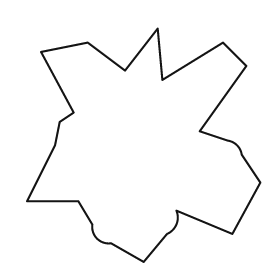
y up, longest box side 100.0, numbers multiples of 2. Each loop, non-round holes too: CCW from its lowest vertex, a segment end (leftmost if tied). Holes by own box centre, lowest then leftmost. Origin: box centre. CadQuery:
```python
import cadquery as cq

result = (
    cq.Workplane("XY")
    .moveTo(0.0, -50.0)
    .lineTo(10.0, -38.0)
    .threePointArc((14.0, -34.0), (14.0, -28.0))
    .lineTo(38.0, -38.0)
    .lineTo(50.0, -16.0)
    .lineTo(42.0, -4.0)
    .threePointArc((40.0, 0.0), (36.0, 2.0))
    .lineTo(24.0, 6.0)
    .lineTo(44.0, 34.0)
    .lineTo(34.0, 44.0)
    .lineTo(8.0, 28.0)
    .lineTo(6.0, 50.0)
    .lineTo(-8.0, 32.0)
    .lineTo(-24.0, 44.0)
    .lineTo(-44.0, 40.0)
    .lineTo(-30.0, 14.0)
    .lineTo(-36.0, 10.0)
    .lineTo(-38.0, 0.0)
    .lineTo(-50.0, -24.0)
    .lineTo(-28.0, -24.0)
    .lineTo(-22.0, -34.0)
    .threePointArc((-20.0, -40.0), (-14.0, -42.0))
    .close()
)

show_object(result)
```